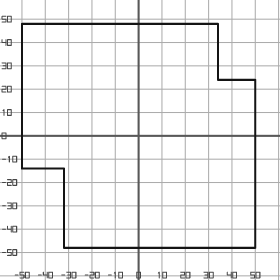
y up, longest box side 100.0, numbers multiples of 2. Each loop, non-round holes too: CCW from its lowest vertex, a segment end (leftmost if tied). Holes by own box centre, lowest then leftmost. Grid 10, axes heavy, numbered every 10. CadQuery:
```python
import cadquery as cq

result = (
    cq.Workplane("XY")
    .moveTo(-32.0, -48.0)
    .lineTo(50.0, -48.0)
    .lineTo(50.0, 24.0)
    .lineTo(34.0, 24.0)
    .lineTo(34.0, 48.0)
    .lineTo(-50.0, 48.0)
    .lineTo(-50.0, -14.0)
    .lineTo(-32.0, -14.0)
    .close()
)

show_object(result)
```